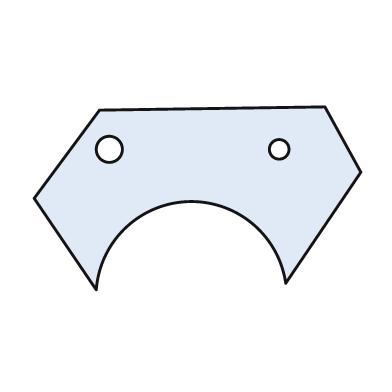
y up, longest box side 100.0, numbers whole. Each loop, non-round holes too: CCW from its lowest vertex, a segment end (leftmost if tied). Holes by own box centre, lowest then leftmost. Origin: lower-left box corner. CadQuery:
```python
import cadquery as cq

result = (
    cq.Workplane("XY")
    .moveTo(19.0, 0.0)
    .threePointArc((47.0, 27.0), (77.0, 2.0))
    .lineTo(100.0, 36.0)
    .lineTo(89.0, 56.0)
    .lineTo(20.0, 55.0)
    .lineTo(0.0, 28.0)
    .close()
    .moveTo(23.0, 43.0)
    .circle(4.0)
    .moveTo(75.0, 43.0)
    .circle(3.0)
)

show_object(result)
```